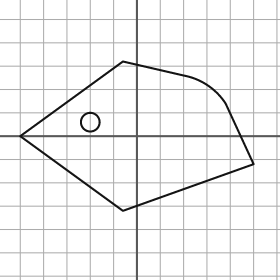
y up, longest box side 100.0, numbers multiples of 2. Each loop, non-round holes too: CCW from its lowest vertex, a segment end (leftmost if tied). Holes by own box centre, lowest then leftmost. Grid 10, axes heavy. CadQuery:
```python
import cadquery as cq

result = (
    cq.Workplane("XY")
    .moveTo(-6.0, -32.0)
    .lineTo(50.0, -12.0)
    .lineTo(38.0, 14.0)
    .threePointArc((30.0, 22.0), (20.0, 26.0))
    .lineTo(-6.0, 32.0)
    .lineTo(-50.0, 0.0)
    .close()
    .moveTo(-20.0, 6.0)
    .circle(4.0)
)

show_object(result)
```